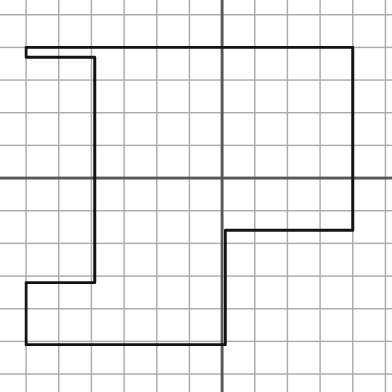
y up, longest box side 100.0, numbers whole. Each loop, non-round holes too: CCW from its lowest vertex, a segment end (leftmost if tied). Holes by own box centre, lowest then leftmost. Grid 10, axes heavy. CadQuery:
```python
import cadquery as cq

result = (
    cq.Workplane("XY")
    .moveTo(-60.0, -51.0)
    .lineTo(1.0, -51.0)
    .lineTo(1.0, -16.0)
    .lineTo(40.0, -16.0)
    .lineTo(40.0, 40.0)
    .lineTo(-60.0, 40.0)
    .lineTo(-60.0, 37.0)
    .lineTo(-39.0, 37.0)
    .lineTo(-39.0, -32.0)
    .lineTo(-60.0, -32.0)
    .close()
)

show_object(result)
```